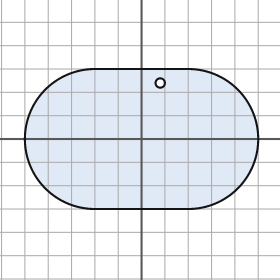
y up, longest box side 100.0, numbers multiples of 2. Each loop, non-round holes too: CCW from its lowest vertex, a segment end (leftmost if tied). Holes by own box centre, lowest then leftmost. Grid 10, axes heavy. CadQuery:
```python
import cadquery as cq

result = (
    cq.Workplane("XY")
    .moveTo(-20.0, -30.0)
    .lineTo(20.0, -30.0)
    .threePointArc((50.0, 0.0), (20.0, 30.0))
    .lineTo(-20.0, 30.0)
    .threePointArc((-50.0, 0.0), (-20.0, -30.0))
    .close()
    .moveTo(8.0, 24.0)
    .circle(2.0)
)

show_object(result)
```